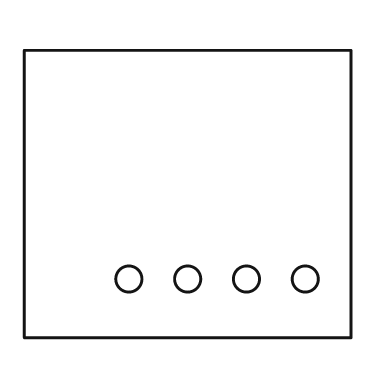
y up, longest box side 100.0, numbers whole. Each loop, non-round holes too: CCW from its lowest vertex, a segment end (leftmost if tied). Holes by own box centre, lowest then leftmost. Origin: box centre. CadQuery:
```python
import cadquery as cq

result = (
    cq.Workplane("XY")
    .moveTo(-50.0, -44.0)
    .lineTo(50.0, -44.0)
    .lineTo(50.0, 44.0)
    .lineTo(-50.0, 44.0)
    .close()
    .moveTo(-18.0, -26.0)
    .circle(4.0)
    .moveTo(0.0, -26.0)
    .circle(4.0)
    .moveTo(18.0, -26.0)
    .circle(4.0)
    .moveTo(36.0, -26.0)
    .circle(4.0)
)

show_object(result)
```